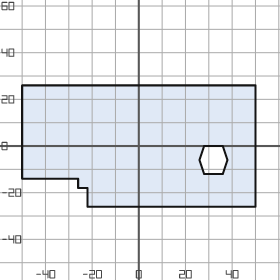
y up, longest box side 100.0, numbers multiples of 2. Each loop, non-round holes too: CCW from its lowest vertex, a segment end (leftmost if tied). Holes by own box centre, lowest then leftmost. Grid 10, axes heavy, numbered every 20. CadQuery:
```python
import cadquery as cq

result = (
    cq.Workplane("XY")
    .moveTo(-22.0, -26.0)
    .lineTo(50.0, -26.0)
    .lineTo(50.0, 26.0)
    .lineTo(-50.0, 26.0)
    .lineTo(-50.0, -14.0)
    .lineTo(-26.0, -14.0)
    .lineTo(-26.0, -18.0)
    .lineTo(-22.0, -18.0)
    .close()
    .moveTo(28.0, -12.0)
    .lineTo(36.0, -12.0)
    .lineTo(38.0, -6.0)
    .lineTo(36.0, 0.0)
    .lineTo(28.0, 0.0)
    .lineTo(26.0, -6.0)
    .close()
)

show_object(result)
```